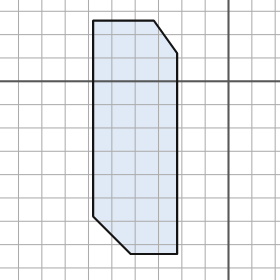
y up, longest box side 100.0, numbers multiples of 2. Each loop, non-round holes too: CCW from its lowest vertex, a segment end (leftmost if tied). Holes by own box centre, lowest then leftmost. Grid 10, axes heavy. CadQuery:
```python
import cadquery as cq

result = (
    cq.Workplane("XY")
    .moveTo(-42.0, -74.0)
    .lineTo(-22.0, -74.0)
    .lineTo(-22.0, 12.0)
    .lineTo(-32.0, 26.0)
    .lineTo(-58.0, 26.0)
    .lineTo(-58.0, -58.0)
    .close()
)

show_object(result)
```